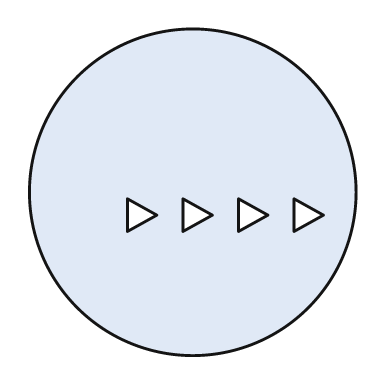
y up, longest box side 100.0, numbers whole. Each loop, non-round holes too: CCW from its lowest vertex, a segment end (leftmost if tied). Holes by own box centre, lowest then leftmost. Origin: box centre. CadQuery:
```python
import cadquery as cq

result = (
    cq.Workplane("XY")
    .moveTo(0.0, 0.0)
    .circle(50.0)
    .moveTo(-20.0, -12.0)
    .lineTo(-11.0, -7.0)
    .lineTo(-20.0, -2.0)
    .close()
    .moveTo(-3.0, -12.0)
    .lineTo(6.0, -7.0)
    .lineTo(-3.0, -2.0)
    .close()
    .moveTo(14.0, -12.0)
    .lineTo(23.0, -7.0)
    .lineTo(14.0, -2.0)
    .close()
    .moveTo(31.0, -12.0)
    .lineTo(40.0, -7.0)
    .lineTo(31.0, -2.0)
    .close()
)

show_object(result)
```